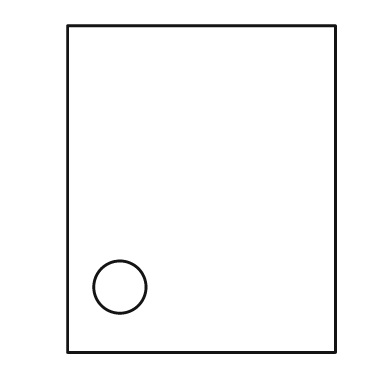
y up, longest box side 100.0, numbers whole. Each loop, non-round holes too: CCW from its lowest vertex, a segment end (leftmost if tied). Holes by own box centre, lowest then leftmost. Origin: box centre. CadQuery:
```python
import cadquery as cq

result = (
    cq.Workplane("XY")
    .moveTo(-41.0, -50.0)
    .lineTo(41.0, -50.0)
    .lineTo(41.0, 50.0)
    .lineTo(-41.0, 50.0)
    .close()
    .moveTo(-25.0, -30.0)
    .circle(8.0)
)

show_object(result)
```